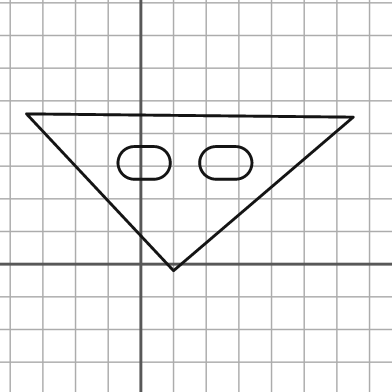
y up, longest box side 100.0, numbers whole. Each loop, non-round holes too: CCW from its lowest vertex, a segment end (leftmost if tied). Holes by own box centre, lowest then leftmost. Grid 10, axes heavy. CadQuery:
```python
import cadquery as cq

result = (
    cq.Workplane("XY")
    .moveTo(10.0, -2.0)
    .lineTo(65.0, 45.0)
    .lineTo(-35.0, 46.0)
    .close()
    .moveTo(-2.0, 26.0)
    .lineTo(4.0, 26.0)
    .threePointArc((9.0, 31.0), (4.0, 36.0))
    .lineTo(-2.0, 36.0)
    .threePointArc((-7.0, 31.0), (-2.0, 26.0))
    .close()
    .moveTo(23.0, 26.0)
    .lineTo(29.0, 26.0)
    .threePointArc((34.0, 31.0), (29.0, 36.0))
    .lineTo(23.0, 36.0)
    .threePointArc((18.0, 31.0), (23.0, 26.0))
    .close()
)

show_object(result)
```